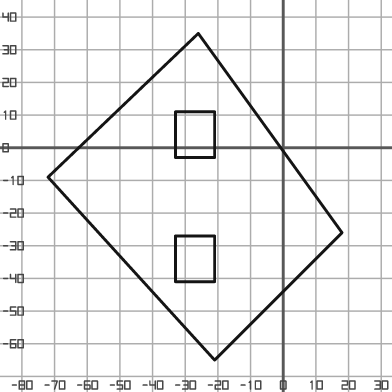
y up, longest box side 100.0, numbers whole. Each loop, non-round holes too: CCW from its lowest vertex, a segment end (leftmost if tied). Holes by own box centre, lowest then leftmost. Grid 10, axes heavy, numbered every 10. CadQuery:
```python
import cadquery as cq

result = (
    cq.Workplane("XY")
    .moveTo(-21.0, -65.0)
    .lineTo(18.0, -26.0)
    .lineTo(-26.0, 35.0)
    .lineTo(-72.0, -9.0)
    .close()
    .moveTo(-33.0, -41.0)
    .lineTo(-21.0, -41.0)
    .lineTo(-21.0, -27.0)
    .lineTo(-33.0, -27.0)
    .close()
    .moveTo(-33.0, -3.0)
    .lineTo(-21.0, -3.0)
    .lineTo(-21.0, 11.0)
    .lineTo(-33.0, 11.0)
    .close()
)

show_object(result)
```